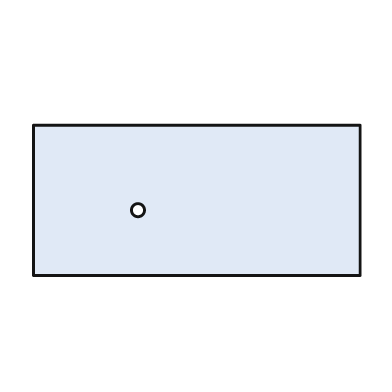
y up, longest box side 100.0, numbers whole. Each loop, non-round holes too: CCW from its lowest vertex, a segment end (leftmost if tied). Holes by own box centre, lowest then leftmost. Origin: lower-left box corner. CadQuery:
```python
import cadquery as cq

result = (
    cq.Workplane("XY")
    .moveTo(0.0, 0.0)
    .lineTo(100.0, 0.0)
    .lineTo(100.0, 46.0)
    .lineTo(0.0, 46.0)
    .close()
    .moveTo(32.0, 20.0)
    .circle(2.0)
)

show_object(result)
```